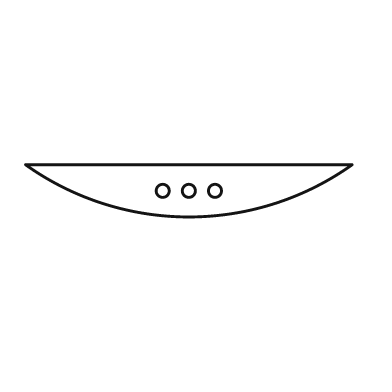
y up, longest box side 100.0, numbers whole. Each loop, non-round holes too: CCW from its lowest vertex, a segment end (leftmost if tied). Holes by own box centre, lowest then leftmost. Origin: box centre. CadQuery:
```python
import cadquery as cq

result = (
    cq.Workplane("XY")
    .moveTo(-50.0, 8.0)
    .threePointArc((0.0, -8.0), (50.0, 8.0))
    .close()
    .moveTo(-8.0, 0.0)
    .circle(2.0)
    .moveTo(0.0, 0.0)
    .circle(2.0)
    .moveTo(8.0, 0.0)
    .circle(2.0)
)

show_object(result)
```